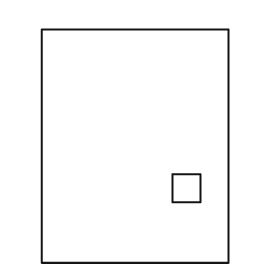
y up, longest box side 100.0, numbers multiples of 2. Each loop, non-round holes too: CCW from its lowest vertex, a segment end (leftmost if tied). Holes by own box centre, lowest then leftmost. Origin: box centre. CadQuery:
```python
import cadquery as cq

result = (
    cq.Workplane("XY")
    .moveTo(-40.0, -50.0)
    .lineTo(40.0, -50.0)
    .lineTo(40.0, 50.0)
    .lineTo(-40.0, 50.0)
    .close()
    .moveTo(16.0, -24.0)
    .lineTo(28.0, -24.0)
    .lineTo(28.0, -12.0)
    .lineTo(16.0, -12.0)
    .close()
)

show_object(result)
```